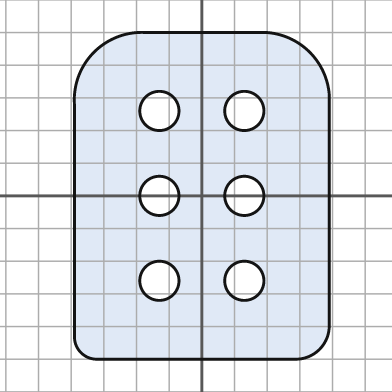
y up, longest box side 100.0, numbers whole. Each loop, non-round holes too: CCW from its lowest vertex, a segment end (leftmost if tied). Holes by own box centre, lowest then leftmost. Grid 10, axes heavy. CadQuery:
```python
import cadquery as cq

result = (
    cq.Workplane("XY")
    .moveTo(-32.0, -50.0)
    .lineTo(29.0, -50.0)
    .threePointArc((36.0, -47.0), (39.0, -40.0))
    .lineTo(39.0, 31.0)
    .threePointArc((33.0, 44.0), (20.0, 50.0))
    .lineTo(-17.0, 50.0)
    .threePointArc((-33.0, 44.0), (-39.0, 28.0))
    .lineTo(-39.0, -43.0)
    .threePointArc((-37.0, -48.0), (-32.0, -50.0))
    .close()
    .moveTo(-13.0, -26.0)
    .circle(6.0)
    .moveTo(13.0, -26.0)
    .circle(6.0)
    .moveTo(-13.0, 0.0)
    .circle(6.0)
    .moveTo(13.0, 0.0)
    .circle(6.0)
    .moveTo(-13.0, 26.0)
    .circle(6.0)
    .moveTo(13.0, 26.0)
    .circle(6.0)
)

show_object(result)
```